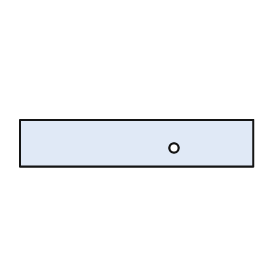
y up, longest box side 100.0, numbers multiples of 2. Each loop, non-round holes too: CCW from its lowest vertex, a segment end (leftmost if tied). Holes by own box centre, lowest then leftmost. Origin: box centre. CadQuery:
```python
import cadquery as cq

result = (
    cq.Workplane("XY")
    .moveTo(-50.0, -10.0)
    .lineTo(50.0, -10.0)
    .lineTo(50.0, 10.0)
    .lineTo(-50.0, 10.0)
    .close()
    .moveTo(16.0, -2.0)
    .circle(2.0)
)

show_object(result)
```